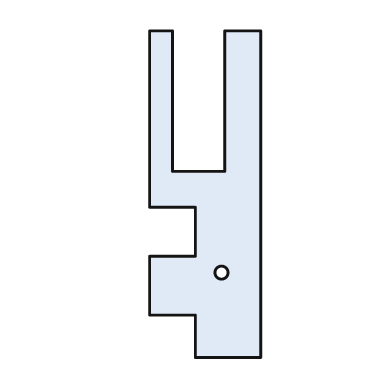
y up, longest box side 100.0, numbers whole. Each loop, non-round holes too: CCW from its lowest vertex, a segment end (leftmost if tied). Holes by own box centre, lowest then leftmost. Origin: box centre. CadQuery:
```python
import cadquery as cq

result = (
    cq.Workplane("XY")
    .moveTo(-3.0, -50.0)
    .lineTo(17.0, -50.0)
    .lineTo(17.0, 50.0)
    .lineTo(6.0, 50.0)
    .lineTo(6.0, 7.0)
    .lineTo(-10.0, 7.0)
    .lineTo(-10.0, 50.0)
    .lineTo(-17.0, 50.0)
    .lineTo(-17.0, -4.0)
    .lineTo(-3.0, -4.0)
    .lineTo(-3.0, -19.0)
    .lineTo(-17.0, -19.0)
    .lineTo(-17.0, -37.0)
    .lineTo(-3.0, -37.0)
    .close()
    .moveTo(5.0, -24.0)
    .circle(2.0)
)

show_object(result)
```